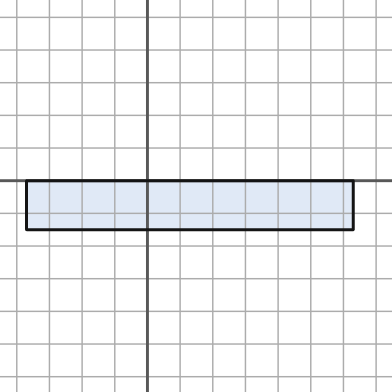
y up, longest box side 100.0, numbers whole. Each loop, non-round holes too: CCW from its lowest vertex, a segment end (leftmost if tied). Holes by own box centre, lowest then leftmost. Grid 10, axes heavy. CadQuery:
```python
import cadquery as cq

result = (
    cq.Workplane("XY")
    .moveTo(-37.0, -15.0)
    .lineTo(63.0, -15.0)
    .lineTo(63.0, 0.0)
    .lineTo(-37.0, 0.0)
    .close()
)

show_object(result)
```